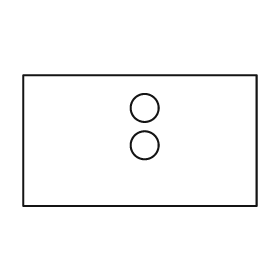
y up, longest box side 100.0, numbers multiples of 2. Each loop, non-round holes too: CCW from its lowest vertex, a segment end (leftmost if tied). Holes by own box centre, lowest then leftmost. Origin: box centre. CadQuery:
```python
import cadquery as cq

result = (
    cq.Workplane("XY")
    .moveTo(-50.0, -28.0)
    .lineTo(50.0, -28.0)
    .lineTo(50.0, 28.0)
    .lineTo(-50.0, 28.0)
    .close()
    .moveTo(2.0, -2.0)
    .circle(6.0)
    .moveTo(2.0, 14.0)
    .circle(6.0)
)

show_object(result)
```